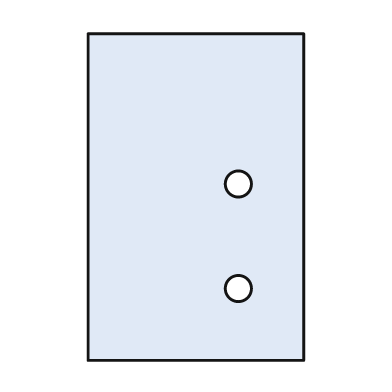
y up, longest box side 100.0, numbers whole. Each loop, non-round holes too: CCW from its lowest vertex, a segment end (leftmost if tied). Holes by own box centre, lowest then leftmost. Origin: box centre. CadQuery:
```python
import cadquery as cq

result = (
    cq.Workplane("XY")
    .moveTo(-33.0, -50.0)
    .lineTo(33.0, -50.0)
    .lineTo(33.0, 50.0)
    .lineTo(-33.0, 50.0)
    .close()
    .moveTo(13.0, -28.0)
    .circle(4.0)
    .moveTo(13.0, 4.0)
    .circle(4.0)
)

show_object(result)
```